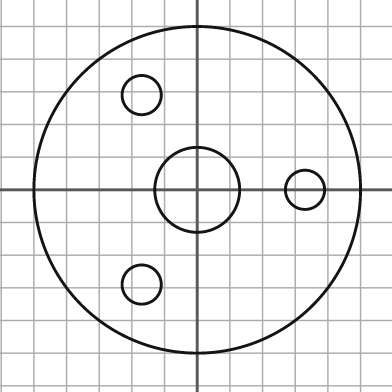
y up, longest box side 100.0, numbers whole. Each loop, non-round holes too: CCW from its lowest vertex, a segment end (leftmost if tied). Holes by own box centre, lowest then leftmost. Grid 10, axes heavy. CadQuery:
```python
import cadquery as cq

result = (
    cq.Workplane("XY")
    .moveTo(0.0, 0.0)
    .circle(50.0)
    .moveTo(-17.0, -29.0)
    .circle(6.0)
    .moveTo(0.0, 0.0)
    .circle(13.0)
    .moveTo(33.0, 0.0)
    .circle(6.0)
    .moveTo(-17.0, 29.0)
    .circle(6.0)
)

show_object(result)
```